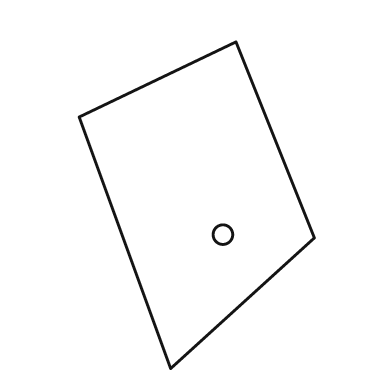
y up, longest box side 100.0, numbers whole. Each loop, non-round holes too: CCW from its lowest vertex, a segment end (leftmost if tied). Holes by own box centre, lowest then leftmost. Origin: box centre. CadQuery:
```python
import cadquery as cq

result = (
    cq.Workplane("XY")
    .moveTo(-8.0, -50.0)
    .lineTo(36.0, -10.0)
    .lineTo(12.0, 50.0)
    .lineTo(-36.0, 27.0)
    .close()
    .moveTo(8.0, -9.0)
    .circle(3.0)
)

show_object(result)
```